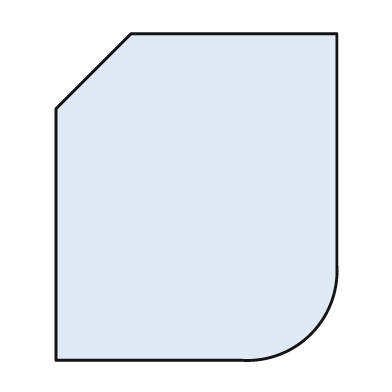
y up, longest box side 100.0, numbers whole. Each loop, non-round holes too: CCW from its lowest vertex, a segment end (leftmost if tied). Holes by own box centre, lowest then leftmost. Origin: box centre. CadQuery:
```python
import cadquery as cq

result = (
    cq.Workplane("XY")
    .moveTo(-43.0, -50.0)
    .lineTo(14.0, -50.0)
    .threePointArc((35.0, -42.0), (43.0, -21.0))
    .lineTo(43.0, 50.0)
    .lineTo(-20.0, 50.0)
    .lineTo(-43.0, 27.0)
    .close()
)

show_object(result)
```